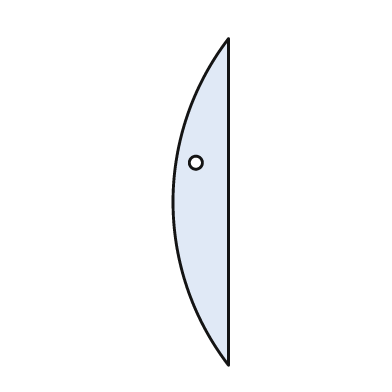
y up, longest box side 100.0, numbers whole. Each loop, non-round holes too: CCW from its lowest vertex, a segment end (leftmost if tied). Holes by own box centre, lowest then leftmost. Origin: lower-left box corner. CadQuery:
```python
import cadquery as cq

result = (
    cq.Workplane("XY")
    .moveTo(17.0, 0.0)
    .lineTo(17.0, 100.0)
    .threePointArc((0.0, 50.0), (17.0, 0.0))
    .close()
    .moveTo(7.0, 62.0)
    .circle(2.0)
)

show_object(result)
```